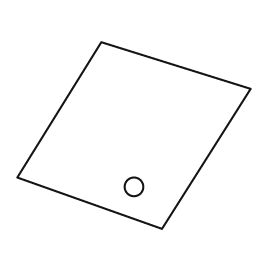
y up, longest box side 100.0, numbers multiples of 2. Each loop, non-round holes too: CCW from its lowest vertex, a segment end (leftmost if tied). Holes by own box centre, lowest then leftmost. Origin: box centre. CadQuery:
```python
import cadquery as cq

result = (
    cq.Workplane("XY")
    .moveTo(12.0, -40.0)
    .lineTo(50.0, 20.0)
    .lineTo(-14.0, 40.0)
    .lineTo(-50.0, -18.0)
    .close()
    .moveTo(0.0, -22.0)
    .circle(4.0)
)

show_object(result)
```